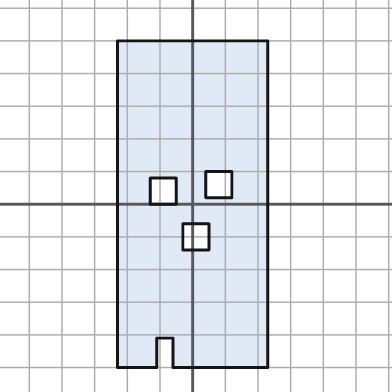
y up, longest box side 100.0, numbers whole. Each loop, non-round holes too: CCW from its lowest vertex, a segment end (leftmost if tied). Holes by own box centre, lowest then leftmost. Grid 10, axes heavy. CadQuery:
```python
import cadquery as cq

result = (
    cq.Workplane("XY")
    .moveTo(-23.0, -50.0)
    .lineTo(-11.0, -50.0)
    .lineTo(-11.0, -41.0)
    .lineTo(-6.0, -41.0)
    .lineTo(-6.0, -50.0)
    .lineTo(23.0, -50.0)
    .lineTo(23.0, 50.0)
    .lineTo(-23.0, 50.0)
    .close()
    .moveTo(-3.0, -14.0)
    .lineTo(5.0, -14.0)
    .lineTo(5.0, -6.0)
    .lineTo(-3.0, -6.0)
    .close()
    .moveTo(-13.0, 0.0)
    .lineTo(-5.0, 0.0)
    .lineTo(-5.0, 8.0)
    .lineTo(-13.0, 8.0)
    .close()
    .moveTo(4.0, 2.0)
    .lineTo(12.0, 2.0)
    .lineTo(12.0, 10.0)
    .lineTo(4.0, 10.0)
    .close()
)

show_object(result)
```